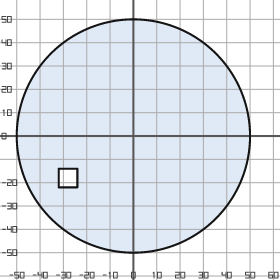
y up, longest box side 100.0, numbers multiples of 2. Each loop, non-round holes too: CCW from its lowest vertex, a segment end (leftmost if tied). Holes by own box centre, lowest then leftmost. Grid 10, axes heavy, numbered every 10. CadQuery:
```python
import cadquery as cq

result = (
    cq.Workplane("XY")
    .moveTo(0.0, 0.0)
    .circle(50.0)
    .moveTo(-32.0, -22.0)
    .lineTo(-24.0, -22.0)
    .lineTo(-24.0, -14.0)
    .lineTo(-32.0, -14.0)
    .close()
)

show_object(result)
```